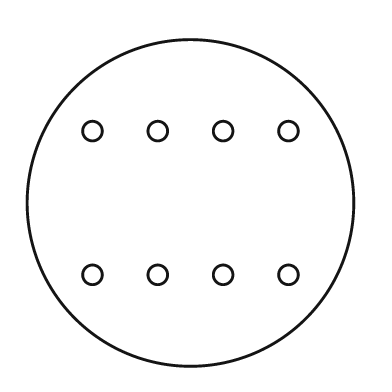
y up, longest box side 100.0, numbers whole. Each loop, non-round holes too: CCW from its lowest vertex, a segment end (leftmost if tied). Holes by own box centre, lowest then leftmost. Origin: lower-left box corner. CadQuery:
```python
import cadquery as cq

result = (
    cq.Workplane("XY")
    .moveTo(50.0, 50.0)
    .circle(50.0)
    .moveTo(20.0, 28.0)
    .circle(3.0)
    .moveTo(40.0, 28.0)
    .circle(3.0)
    .moveTo(60.0, 28.0)
    .circle(3.0)
    .moveTo(80.0, 28.0)
    .circle(3.0)
    .moveTo(20.0, 72.0)
    .circle(3.0)
    .moveTo(40.0, 72.0)
    .circle(3.0)
    .moveTo(60.0, 72.0)
    .circle(3.0)
    .moveTo(80.0, 72.0)
    .circle(3.0)
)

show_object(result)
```